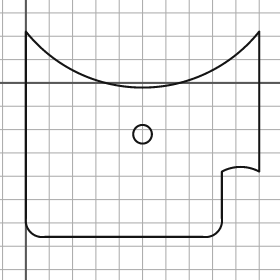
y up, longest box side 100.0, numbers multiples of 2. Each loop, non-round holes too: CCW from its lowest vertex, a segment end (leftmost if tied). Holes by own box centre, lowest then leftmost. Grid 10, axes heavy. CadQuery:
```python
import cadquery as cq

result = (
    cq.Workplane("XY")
    .moveTo(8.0, -66.0)
    .lineTo(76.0, -66.0)
    .threePointArc((82.0, -64.0), (84.0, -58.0))
    .lineTo(84.0, -38.0)
    .threePointArc((92.0, -36.0), (100.0, -38.0))
    .lineTo(100.0, 22.0)
    .threePointArc((50.0, -2.0), (0.0, 22.0))
    .lineTo(0.0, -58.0)
    .threePointArc((2.0, -64.0), (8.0, -66.0))
    .close()
    .moveTo(50.0, -22.0)
    .circle(4.0)
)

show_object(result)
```